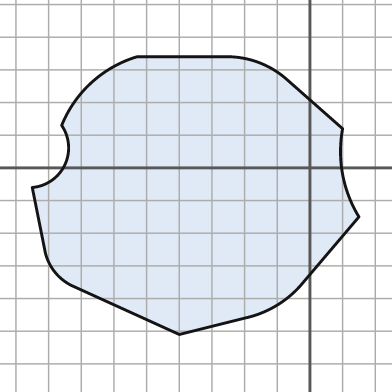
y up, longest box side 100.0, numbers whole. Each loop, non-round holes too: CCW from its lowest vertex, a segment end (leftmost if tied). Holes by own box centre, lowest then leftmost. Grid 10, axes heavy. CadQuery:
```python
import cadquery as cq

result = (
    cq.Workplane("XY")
    .moveTo(-40.0, -51.0)
    .lineTo(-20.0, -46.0)
    .threePointArc((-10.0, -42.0), (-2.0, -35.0))
    .lineTo(15.0, -15.0)
    .threePointArc((10.0, -2.0), (10.0, 12.0))
    .lineTo(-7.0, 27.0)
    .threePointArc((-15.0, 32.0), (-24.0, 34.0))
    .lineTo(-53.0, 34.0)
    .threePointArc((-67.0, 26.0), (-76.0, 13.0))
    .threePointArc((-75.0, 1.0), (-85.0, -6.0))
    .lineTo(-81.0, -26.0)
    .threePointArc((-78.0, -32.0), (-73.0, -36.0))
    .close()
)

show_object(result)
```